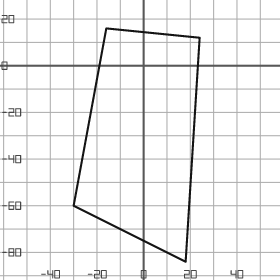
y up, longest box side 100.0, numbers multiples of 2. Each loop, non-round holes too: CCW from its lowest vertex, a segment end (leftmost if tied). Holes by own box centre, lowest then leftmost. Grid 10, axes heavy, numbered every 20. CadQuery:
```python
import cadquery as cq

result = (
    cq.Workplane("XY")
    .moveTo(18.0, -84.0)
    .lineTo(24.0, 12.0)
    .lineTo(-16.0, 16.0)
    .lineTo(-30.0, -60.0)
    .close()
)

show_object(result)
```